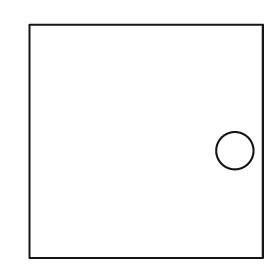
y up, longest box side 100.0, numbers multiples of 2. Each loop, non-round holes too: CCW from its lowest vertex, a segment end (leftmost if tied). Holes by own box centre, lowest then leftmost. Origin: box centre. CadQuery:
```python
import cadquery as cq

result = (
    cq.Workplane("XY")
    .moveTo(-50.0, -50.0)
    .lineTo(50.0, -50.0)
    .lineTo(50.0, 50.0)
    .lineTo(-50.0, 50.0)
    .close()
    .moveTo(38.0, -4.0)
    .circle(8.0)
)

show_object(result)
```